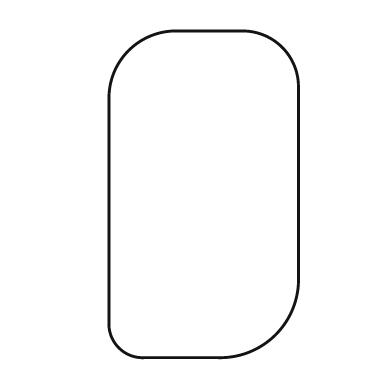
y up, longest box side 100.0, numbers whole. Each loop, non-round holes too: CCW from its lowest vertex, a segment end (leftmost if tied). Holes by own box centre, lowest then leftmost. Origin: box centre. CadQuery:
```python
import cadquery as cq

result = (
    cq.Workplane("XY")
    .moveTo(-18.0, -50.0)
    .lineTo(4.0, -50.0)
    .threePointArc((22.0, -43.0), (29.0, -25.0))
    .lineTo(29.0, 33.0)
    .threePointArc((24.0, 45.0), (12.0, 50.0))
    .lineTo(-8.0, 50.0)
    .threePointArc((-23.0, 44.0), (-29.0, 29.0))
    .lineTo(-29.0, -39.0)
    .threePointArc((-26.0, -47.0), (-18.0, -50.0))
    .close()
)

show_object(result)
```